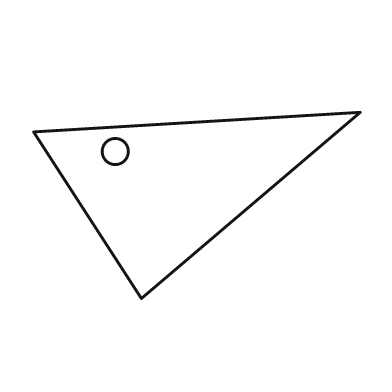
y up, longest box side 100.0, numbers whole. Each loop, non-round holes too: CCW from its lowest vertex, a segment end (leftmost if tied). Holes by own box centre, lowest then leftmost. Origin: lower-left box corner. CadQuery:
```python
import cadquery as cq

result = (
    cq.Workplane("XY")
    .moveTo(33.0, 0.0)
    .lineTo(100.0, 57.0)
    .lineTo(0.0, 51.0)
    .close()
    .moveTo(25.0, 45.0)
    .circle(4.0)
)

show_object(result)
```